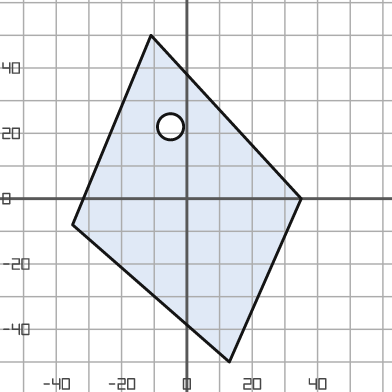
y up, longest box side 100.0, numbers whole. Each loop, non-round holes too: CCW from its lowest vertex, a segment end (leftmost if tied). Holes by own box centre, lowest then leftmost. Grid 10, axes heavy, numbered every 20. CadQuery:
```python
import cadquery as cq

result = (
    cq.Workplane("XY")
    .moveTo(13.0, -50.0)
    .lineTo(35.0, 0.0)
    .lineTo(-11.0, 50.0)
    .lineTo(-35.0, -8.0)
    .close()
    .moveTo(-5.0, 22.0)
    .circle(4.0)
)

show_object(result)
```